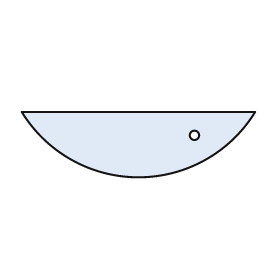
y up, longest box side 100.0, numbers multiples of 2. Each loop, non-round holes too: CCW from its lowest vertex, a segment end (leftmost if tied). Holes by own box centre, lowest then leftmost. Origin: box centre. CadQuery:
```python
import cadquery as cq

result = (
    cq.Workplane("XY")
    .moveTo(-50.0, 14.0)
    .threePointArc((0.0, -14.0), (50.0, 14.0))
    .close()
    .moveTo(24.0, 4.0)
    .circle(2.0)
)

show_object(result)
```